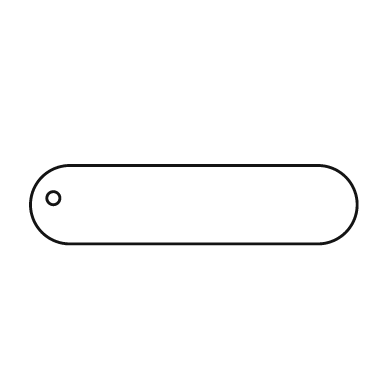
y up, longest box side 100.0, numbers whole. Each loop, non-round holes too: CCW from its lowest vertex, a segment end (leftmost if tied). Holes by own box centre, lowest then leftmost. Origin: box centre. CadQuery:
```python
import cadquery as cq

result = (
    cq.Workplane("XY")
    .moveTo(-38.0, -12.0)
    .lineTo(38.0, -12.0)
    .threePointArc((50.0, 0.0), (38.0, 12.0))
    .lineTo(-38.0, 12.0)
    .threePointArc((-50.0, 0.0), (-38.0, -12.0))
    .close()
    .moveTo(-43.0, 2.0)
    .circle(2.0)
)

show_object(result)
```